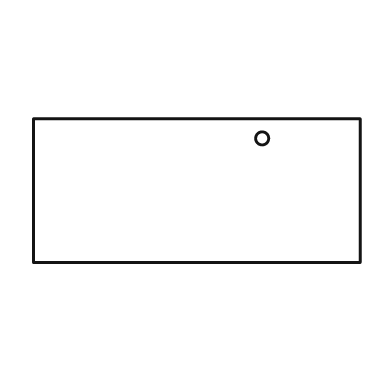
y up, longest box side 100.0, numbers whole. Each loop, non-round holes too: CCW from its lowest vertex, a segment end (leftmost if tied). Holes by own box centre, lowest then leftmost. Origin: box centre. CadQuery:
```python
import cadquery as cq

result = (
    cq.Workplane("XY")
    .moveTo(-50.0, -22.0)
    .lineTo(50.0, -22.0)
    .lineTo(50.0, 22.0)
    .lineTo(-50.0, 22.0)
    .close()
    .moveTo(20.0, 16.0)
    .circle(2.0)
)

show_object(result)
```